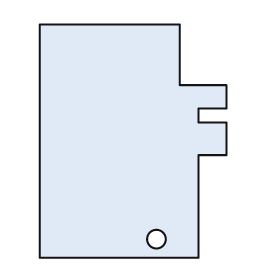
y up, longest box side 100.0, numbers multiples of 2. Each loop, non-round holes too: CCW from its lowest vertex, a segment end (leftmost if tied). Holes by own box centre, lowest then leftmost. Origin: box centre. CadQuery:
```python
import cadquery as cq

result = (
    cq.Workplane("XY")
    .moveTo(-40.0, -50.0)
    .lineTo(28.0, -50.0)
    .lineTo(28.0, -6.0)
    .lineTo(40.0, -6.0)
    .lineTo(40.0, 8.0)
    .lineTo(28.0, 8.0)
    .lineTo(28.0, 14.0)
    .lineTo(40.0, 14.0)
    .lineTo(40.0, 24.0)
    .lineTo(20.0, 24.0)
    .lineTo(20.0, 50.0)
    .lineTo(-40.0, 50.0)
    .close()
    .moveTo(10.0, -42.0)
    .circle(4.0)
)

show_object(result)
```